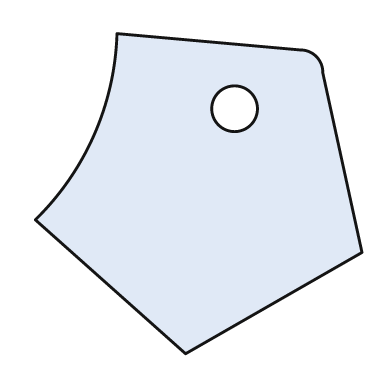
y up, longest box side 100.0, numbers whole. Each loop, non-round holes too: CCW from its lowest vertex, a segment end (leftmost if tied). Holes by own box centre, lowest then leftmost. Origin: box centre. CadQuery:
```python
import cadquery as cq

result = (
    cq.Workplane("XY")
    .moveTo(-4.0, -49.0)
    .lineTo(50.0, -18.0)
    .lineTo(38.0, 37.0)
    .threePointArc((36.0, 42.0), (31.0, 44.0))
    .lineTo(-25.0, 49.0)
    .threePointArc((-32.0, 18.0), (-50.0, -8.0))
    .close()
    .moveTo(11.0, 26.0)
    .circle(7.0)
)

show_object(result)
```